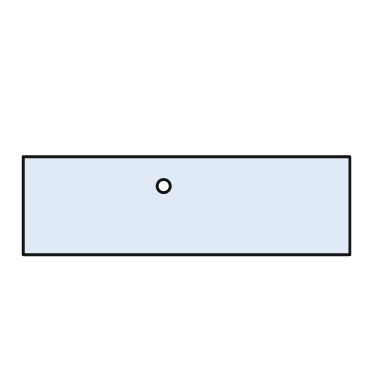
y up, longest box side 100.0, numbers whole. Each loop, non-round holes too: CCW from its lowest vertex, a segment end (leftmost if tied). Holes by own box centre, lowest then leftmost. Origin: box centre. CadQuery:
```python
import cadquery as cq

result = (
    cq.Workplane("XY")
    .moveTo(-50.0, -15.0)
    .lineTo(50.0, -15.0)
    .lineTo(50.0, 15.0)
    .lineTo(-50.0, 15.0)
    .close()
    .moveTo(-7.0, 6.0)
    .circle(2.0)
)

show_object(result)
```